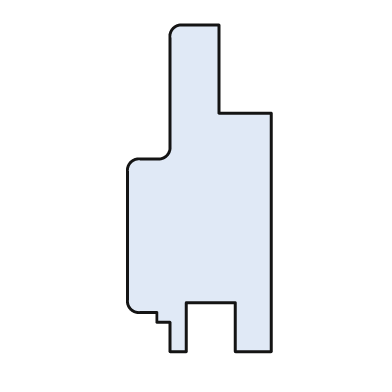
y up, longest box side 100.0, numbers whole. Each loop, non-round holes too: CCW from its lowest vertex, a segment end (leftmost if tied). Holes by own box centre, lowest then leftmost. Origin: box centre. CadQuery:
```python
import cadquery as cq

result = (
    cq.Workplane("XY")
    .moveTo(-9.0, -50.0)
    .lineTo(-4.0, -50.0)
    .lineTo(-4.0, -35.0)
    .lineTo(11.0, -35.0)
    .lineTo(11.0, -50.0)
    .lineTo(22.0, -50.0)
    .lineTo(22.0, 23.0)
    .lineTo(6.0, 23.0)
    .lineTo(6.0, 50.0)
    .lineTo(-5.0, 50.0)
    .threePointArc((-8.0, 49.0), (-9.0, 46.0))
    .lineTo(-9.0, 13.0)
    .threePointArc((-10.0, 10.0), (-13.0, 9.0))
    .lineTo(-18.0, 9.0)
    .threePointArc((-21.0, 8.0), (-22.0, 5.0))
    .lineTo(-22.0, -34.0)
    .threePointArc((-21.0, -37.0), (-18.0, -38.0))
    .lineTo(-13.0, -38.0)
    .lineTo(-13.0, -41.0)
    .lineTo(-9.0, -41.0)
    .close()
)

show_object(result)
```